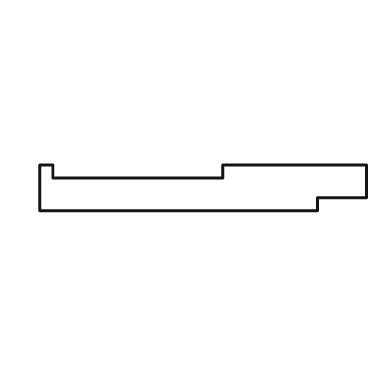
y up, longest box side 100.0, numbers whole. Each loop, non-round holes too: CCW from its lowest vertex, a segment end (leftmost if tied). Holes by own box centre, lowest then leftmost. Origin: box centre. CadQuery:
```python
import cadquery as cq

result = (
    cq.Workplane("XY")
    .moveTo(-50.0, -7.0)
    .lineTo(35.0, -7.0)
    .lineTo(35.0, -3.0)
    .lineTo(50.0, -3.0)
    .lineTo(50.0, 7.0)
    .lineTo(6.0, 7.0)
    .lineTo(6.0, 3.0)
    .lineTo(-46.0, 3.0)
    .lineTo(-46.0, 7.0)
    .lineTo(-50.0, 7.0)
    .close()
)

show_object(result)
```